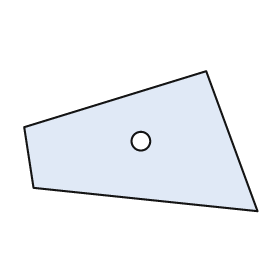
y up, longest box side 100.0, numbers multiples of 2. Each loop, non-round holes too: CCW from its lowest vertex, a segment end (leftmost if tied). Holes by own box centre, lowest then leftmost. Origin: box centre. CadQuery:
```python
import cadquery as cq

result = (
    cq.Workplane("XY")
    .moveTo(50.0, -30.0)
    .lineTo(28.0, 30.0)
    .lineTo(-50.0, 6.0)
    .lineTo(-46.0, -20.0)
    .close()
    .moveTo(0.0, 0.0)
    .circle(4.0)
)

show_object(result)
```